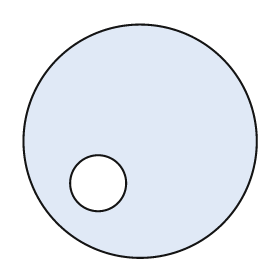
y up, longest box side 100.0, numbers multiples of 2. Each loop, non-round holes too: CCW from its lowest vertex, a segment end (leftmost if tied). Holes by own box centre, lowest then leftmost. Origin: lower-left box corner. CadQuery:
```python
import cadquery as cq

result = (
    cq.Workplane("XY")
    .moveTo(50.0, 50.0)
    .circle(50.0)
    .moveTo(32.0, 32.0)
    .circle(12.0)
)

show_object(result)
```